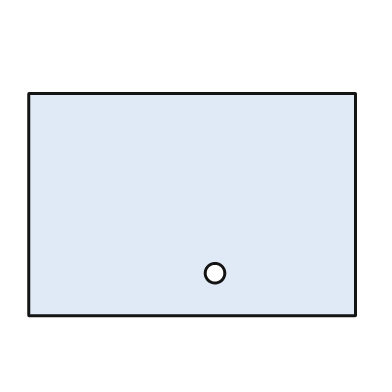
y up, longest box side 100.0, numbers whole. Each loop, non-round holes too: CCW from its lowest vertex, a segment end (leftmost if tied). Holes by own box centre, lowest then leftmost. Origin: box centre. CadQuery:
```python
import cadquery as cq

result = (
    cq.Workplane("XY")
    .moveTo(-50.0, -34.0)
    .lineTo(50.0, -34.0)
    .lineTo(50.0, 34.0)
    .lineTo(-50.0, 34.0)
    .close()
    .moveTo(7.0, -21.0)
    .circle(3.0)
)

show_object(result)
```